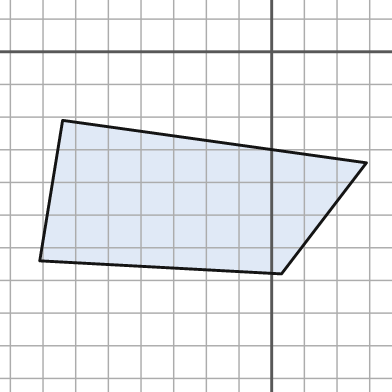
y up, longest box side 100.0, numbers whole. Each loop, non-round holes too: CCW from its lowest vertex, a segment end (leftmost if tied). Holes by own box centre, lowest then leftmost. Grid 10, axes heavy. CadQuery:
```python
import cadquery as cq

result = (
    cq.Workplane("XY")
    .moveTo(3.0, -68.0)
    .lineTo(29.0, -34.0)
    .lineTo(-64.0, -21.0)
    .lineTo(-71.0, -64.0)
    .close()
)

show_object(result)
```